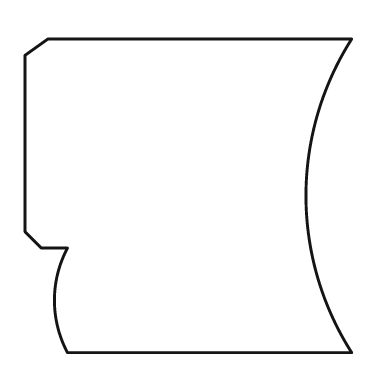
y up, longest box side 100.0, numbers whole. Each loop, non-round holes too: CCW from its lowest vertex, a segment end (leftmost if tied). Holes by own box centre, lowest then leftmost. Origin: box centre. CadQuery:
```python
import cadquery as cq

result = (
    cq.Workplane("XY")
    .moveTo(-37.0, -48.0)
    .lineTo(50.0, -48.0)
    .threePointArc((36.0, 0.0), (50.0, 48.0))
    .lineTo(-43.0, 48.0)
    .lineTo(-50.0, 43.0)
    .lineTo(-50.0, -11.0)
    .lineTo(-45.0, -16.0)
    .lineTo(-37.0, -16.0)
    .threePointArc((-41.0, -32.0), (-37.0, -48.0))
    .close()
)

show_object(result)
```